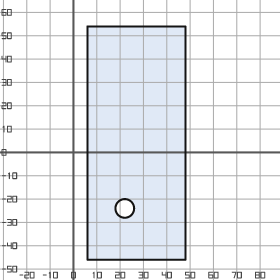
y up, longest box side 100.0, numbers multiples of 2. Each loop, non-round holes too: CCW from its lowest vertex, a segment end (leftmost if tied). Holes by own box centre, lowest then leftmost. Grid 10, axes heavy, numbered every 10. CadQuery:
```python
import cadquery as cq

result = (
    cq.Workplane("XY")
    .moveTo(6.0, -46.0)
    .lineTo(48.0, -46.0)
    .lineTo(48.0, 54.0)
    .lineTo(6.0, 54.0)
    .close()
    .moveTo(22.0, -24.0)
    .circle(4.0)
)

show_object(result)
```